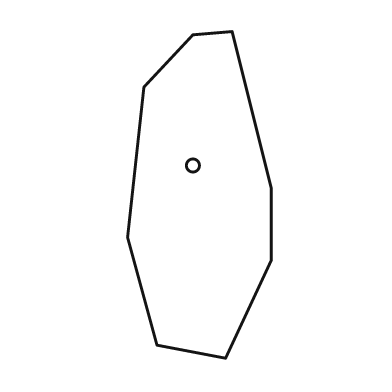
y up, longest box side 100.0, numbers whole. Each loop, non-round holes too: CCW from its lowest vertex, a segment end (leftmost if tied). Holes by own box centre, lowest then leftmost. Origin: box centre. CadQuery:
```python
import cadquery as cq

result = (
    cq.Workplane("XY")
    .moveTo(8.0, -50.0)
    .lineTo(22.0, -20.0)
    .lineTo(22.0, 2.0)
    .lineTo(10.0, 50.0)
    .lineTo(-2.0, 49.0)
    .lineTo(-17.0, 33.0)
    .lineTo(-22.0, -13.0)
    .lineTo(-13.0, -46.0)
    .close()
    .moveTo(-2.0, 9.0)
    .circle(2.0)
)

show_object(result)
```